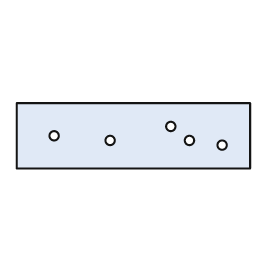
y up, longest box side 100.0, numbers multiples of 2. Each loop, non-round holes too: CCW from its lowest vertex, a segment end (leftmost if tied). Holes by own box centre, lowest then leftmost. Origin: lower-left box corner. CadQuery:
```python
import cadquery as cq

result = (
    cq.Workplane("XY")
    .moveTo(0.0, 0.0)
    .lineTo(100.0, 0.0)
    .lineTo(100.0, 28.0)
    .lineTo(0.0, 28.0)
    .close()
    .moveTo(88.0, 10.0)
    .circle(2.0)
    .moveTo(40.0, 12.0)
    .circle(2.0)
    .moveTo(74.0, 12.0)
    .circle(2.0)
    .moveTo(16.0, 14.0)
    .circle(2.0)
    .moveTo(66.0, 18.0)
    .circle(2.0)
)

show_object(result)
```